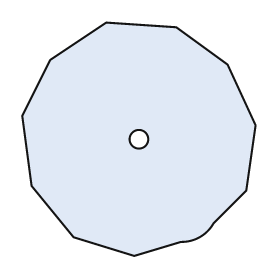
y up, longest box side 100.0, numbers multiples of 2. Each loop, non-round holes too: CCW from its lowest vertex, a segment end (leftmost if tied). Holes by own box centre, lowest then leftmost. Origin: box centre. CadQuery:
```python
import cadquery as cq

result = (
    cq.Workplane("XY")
    .moveTo(-2.0, -50.0)
    .lineTo(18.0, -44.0)
    .threePointArc((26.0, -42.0), (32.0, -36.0))
    .lineTo(46.0, -22.0)
    .lineTo(50.0, 6.0)
    .lineTo(38.0, 32.0)
    .lineTo(16.0, 48.0)
    .lineTo(-14.0, 50.0)
    .lineTo(-38.0, 34.0)
    .lineTo(-50.0, 10.0)
    .lineTo(-46.0, -20.0)
    .lineTo(-28.0, -42.0)
    .close()
    .moveTo(0.0, 0.0)
    .circle(4.0)
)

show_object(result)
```